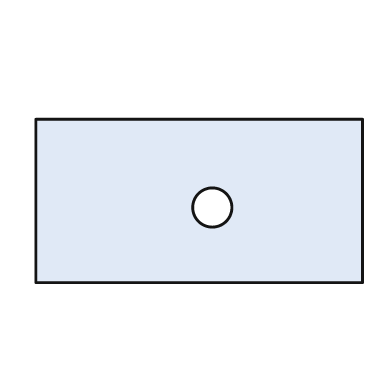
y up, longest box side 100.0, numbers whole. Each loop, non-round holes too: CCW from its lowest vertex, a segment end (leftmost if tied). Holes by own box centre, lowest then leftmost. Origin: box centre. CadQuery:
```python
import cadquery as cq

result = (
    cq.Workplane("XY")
    .moveTo(-50.0, -25.0)
    .lineTo(50.0, -25.0)
    .lineTo(50.0, 25.0)
    .lineTo(-50.0, 25.0)
    .close()
    .moveTo(4.0, -2.0)
    .circle(6.0)
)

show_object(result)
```